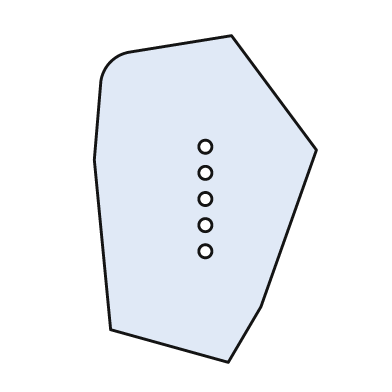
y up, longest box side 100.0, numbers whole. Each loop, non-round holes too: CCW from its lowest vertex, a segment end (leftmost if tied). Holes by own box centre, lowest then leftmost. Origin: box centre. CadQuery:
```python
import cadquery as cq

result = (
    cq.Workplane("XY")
    .moveTo(7.0, -50.0)
    .lineTo(17.0, -33.0)
    .lineTo(34.0, 15.0)
    .lineTo(8.0, 50.0)
    .lineTo(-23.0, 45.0)
    .threePointArc((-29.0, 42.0), (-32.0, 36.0))
    .lineTo(-34.0, 12.0)
    .lineTo(-29.0, -40.0)
    .close()
    .moveTo(0.0, -16.0)
    .circle(2.0)
    .moveTo(0.0, -8.0)
    .circle(2.0)
    .moveTo(0.0, 0.0)
    .circle(2.0)
    .moveTo(0.0, 8.0)
    .circle(2.0)
    .moveTo(0.0, 16.0)
    .circle(2.0)
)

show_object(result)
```